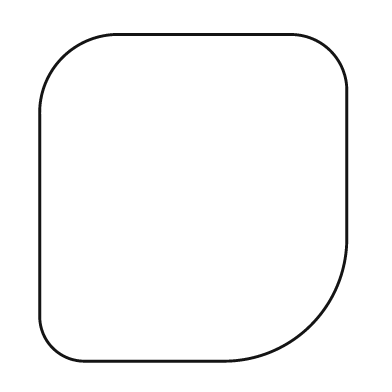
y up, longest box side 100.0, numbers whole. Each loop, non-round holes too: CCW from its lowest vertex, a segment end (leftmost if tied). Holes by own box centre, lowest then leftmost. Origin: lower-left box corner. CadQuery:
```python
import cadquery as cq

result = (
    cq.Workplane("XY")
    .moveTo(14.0, 0.0)
    .lineTo(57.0, 0.0)
    .threePointArc((83.0, 11.0), (94.0, 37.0))
    .lineTo(94.0, 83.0)
    .threePointArc((89.0, 95.0), (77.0, 100.0))
    .lineTo(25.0, 100.0)
    .threePointArc((7.0, 93.0), (0.0, 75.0))
    .lineTo(0.0, 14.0)
    .threePointArc((4.0, 4.0), (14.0, 0.0))
    .close()
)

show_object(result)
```